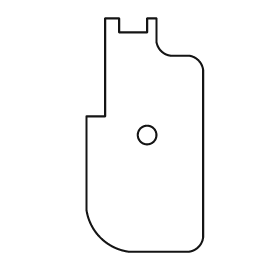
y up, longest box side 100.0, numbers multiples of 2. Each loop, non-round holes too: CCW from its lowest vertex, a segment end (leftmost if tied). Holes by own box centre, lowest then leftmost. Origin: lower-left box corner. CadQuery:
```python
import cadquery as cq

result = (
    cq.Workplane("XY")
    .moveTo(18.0, 0.0)
    .lineTo(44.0, 0.0)
    .threePointArc((48.0, 2.0), (50.0, 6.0))
    .lineTo(50.0, 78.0)
    .threePointArc((48.0, 82.0), (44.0, 84.0))
    .lineTo(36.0, 84.0)
    .threePointArc((32.0, 86.0), (30.0, 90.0))
    .lineTo(30.0, 100.0)
    .lineTo(26.0, 100.0)
    .lineTo(26.0, 94.0)
    .lineTo(14.0, 94.0)
    .lineTo(14.0, 100.0)
    .lineTo(8.0, 100.0)
    .lineTo(8.0, 58.0)
    .lineTo(0.0, 58.0)
    .lineTo(0.0, 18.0)
    .threePointArc((6.0, 6.0), (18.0, 0.0))
    .close()
    .moveTo(26.0, 50.0)
    .circle(4.0)
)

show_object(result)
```